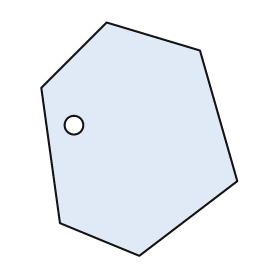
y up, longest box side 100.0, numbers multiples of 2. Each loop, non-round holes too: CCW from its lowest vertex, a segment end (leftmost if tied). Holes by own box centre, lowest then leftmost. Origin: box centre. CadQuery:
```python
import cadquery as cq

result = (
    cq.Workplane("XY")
    .moveTo(0.0, -50.0)
    .lineTo(42.0, -18.0)
    .lineTo(26.0, 38.0)
    .lineTo(-14.0, 50.0)
    .lineTo(-42.0, 22.0)
    .lineTo(-34.0, -36.0)
    .close()
    .moveTo(-28.0, 6.0)
    .circle(4.0)
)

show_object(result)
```